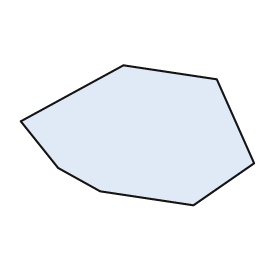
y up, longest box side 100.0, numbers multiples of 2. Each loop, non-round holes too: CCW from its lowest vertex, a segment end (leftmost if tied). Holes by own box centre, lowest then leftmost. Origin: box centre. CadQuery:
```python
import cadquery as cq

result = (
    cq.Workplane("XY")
    .moveTo(24.0, -30.0)
    .lineTo(50.0, -12.0)
    .lineTo(34.0, 24.0)
    .lineTo(-6.0, 30.0)
    .lineTo(-50.0, 6.0)
    .lineTo(-34.0, -14.0)
    .lineTo(-16.0, -24.0)
    .close()
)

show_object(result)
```